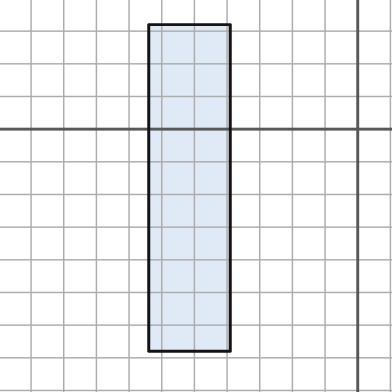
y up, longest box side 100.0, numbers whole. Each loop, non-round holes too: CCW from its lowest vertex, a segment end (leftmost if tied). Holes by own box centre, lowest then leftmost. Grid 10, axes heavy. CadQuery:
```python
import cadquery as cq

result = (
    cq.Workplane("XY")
    .moveTo(-64.0, -68.0)
    .lineTo(-39.0, -68.0)
    .lineTo(-39.0, 32.0)
    .lineTo(-64.0, 32.0)
    .close()
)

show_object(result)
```